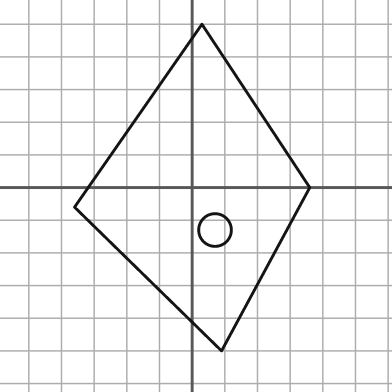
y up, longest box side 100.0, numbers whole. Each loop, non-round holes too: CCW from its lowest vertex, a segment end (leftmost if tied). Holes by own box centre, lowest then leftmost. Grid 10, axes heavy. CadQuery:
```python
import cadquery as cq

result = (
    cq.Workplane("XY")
    .moveTo(9.0, -50.0)
    .lineTo(36.0, 0.0)
    .lineTo(3.0, 50.0)
    .lineTo(-36.0, -6.0)
    .close()
    .moveTo(7.0, -13.0)
    .circle(5.0)
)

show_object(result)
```